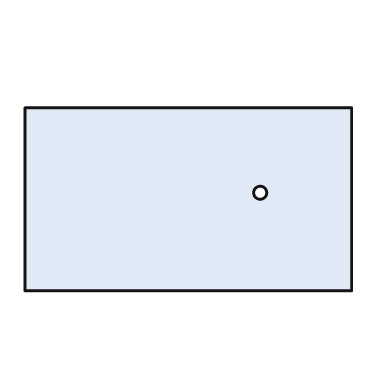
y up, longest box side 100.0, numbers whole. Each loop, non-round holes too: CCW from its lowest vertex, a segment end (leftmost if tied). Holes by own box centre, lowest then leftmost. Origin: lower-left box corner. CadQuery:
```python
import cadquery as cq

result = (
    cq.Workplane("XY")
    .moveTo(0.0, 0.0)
    .lineTo(100.0, 0.0)
    .lineTo(100.0, 56.0)
    .lineTo(0.0, 56.0)
    .close()
    .moveTo(72.0, 30.0)
    .circle(2.0)
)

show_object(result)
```